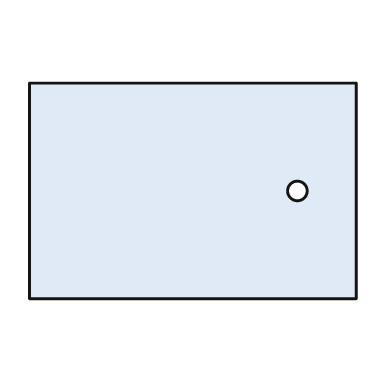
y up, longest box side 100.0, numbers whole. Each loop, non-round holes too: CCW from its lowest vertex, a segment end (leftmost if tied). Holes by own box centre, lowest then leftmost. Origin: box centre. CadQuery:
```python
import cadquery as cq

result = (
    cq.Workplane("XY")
    .moveTo(-50.0, -33.0)
    .lineTo(50.0, -33.0)
    .lineTo(50.0, 33.0)
    .lineTo(-50.0, 33.0)
    .close()
    .moveTo(32.0, 0.0)
    .circle(3.0)
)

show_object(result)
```